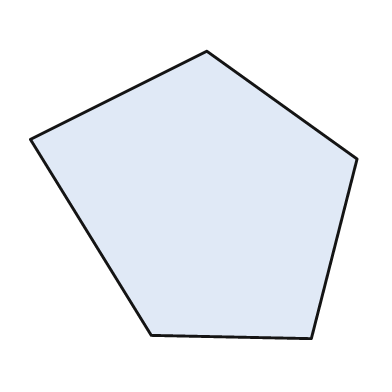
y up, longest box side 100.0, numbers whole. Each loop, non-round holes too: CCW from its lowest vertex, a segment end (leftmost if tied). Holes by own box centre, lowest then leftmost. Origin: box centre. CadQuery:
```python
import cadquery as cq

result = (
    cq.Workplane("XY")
    .moveTo(36.0, -44.0)
    .lineTo(50.0, 11.0)
    .lineTo(4.0, 44.0)
    .lineTo(-50.0, 17.0)
    .lineTo(-13.0, -43.0)
    .close()
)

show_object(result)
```